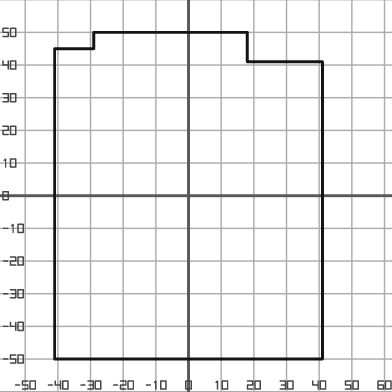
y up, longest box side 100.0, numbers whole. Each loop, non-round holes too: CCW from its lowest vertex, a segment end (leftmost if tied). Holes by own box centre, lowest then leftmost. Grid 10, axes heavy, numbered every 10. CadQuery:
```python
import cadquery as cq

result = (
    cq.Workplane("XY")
    .moveTo(-41.0, -50.0)
    .lineTo(41.0, -50.0)
    .lineTo(41.0, 41.0)
    .lineTo(18.0, 41.0)
    .lineTo(18.0, 50.0)
    .lineTo(-29.0, 50.0)
    .lineTo(-29.0, 45.0)
    .lineTo(-41.0, 45.0)
    .close()
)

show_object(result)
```